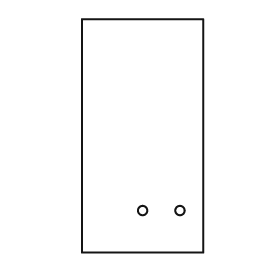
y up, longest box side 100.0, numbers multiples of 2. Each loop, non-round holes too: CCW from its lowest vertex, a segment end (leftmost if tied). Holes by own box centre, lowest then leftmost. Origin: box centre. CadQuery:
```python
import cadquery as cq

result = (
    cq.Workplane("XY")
    .moveTo(-26.0, -50.0)
    .lineTo(26.0, -50.0)
    .lineTo(26.0, 50.0)
    .lineTo(-26.0, 50.0)
    .close()
    .moveTo(0.0, -32.0)
    .circle(2.0)
    .moveTo(16.0, -32.0)
    .circle(2.0)
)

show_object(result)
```